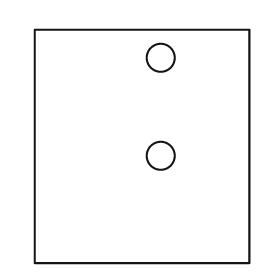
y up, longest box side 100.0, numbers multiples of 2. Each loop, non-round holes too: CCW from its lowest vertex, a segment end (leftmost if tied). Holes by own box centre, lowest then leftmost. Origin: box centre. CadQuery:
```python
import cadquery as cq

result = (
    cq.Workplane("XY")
    .moveTo(-46.0, -50.0)
    .lineTo(46.0, -50.0)
    .lineTo(46.0, 50.0)
    .lineTo(-46.0, 50.0)
    .close()
    .moveTo(8.0, -4.0)
    .circle(6.0)
    .moveTo(8.0, 38.0)
    .circle(6.0)
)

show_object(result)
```